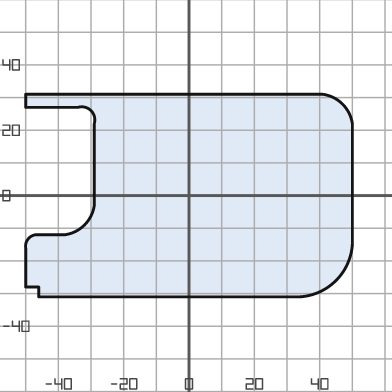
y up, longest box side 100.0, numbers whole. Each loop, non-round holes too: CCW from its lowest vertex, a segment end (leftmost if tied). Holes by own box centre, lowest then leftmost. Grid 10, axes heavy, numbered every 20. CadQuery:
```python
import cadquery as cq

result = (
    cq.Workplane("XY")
    .moveTo(-46.0, -31.0)
    .lineTo(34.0, -31.0)
    .threePointArc((45.0, -26.0), (50.0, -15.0))
    .lineTo(50.0, 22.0)
    .threePointArc((47.0, 28.0), (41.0, 31.0))
    .lineTo(-50.0, 31.0)
    .lineTo(-50.0, 27.0)
    .lineTo(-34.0, 27.0)
    .threePointArc((-30.0, 26.0), (-29.0, 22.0))
    .lineTo(-29.0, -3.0)
    .threePointArc((-32.0, -9.0), (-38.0, -12.0))
    .lineTo(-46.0, -12.0)
    .threePointArc((-49.0, -13.0), (-50.0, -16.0))
    .lineTo(-50.0, -28.0)
    .lineTo(-46.0, -28.0)
    .close()
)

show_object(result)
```